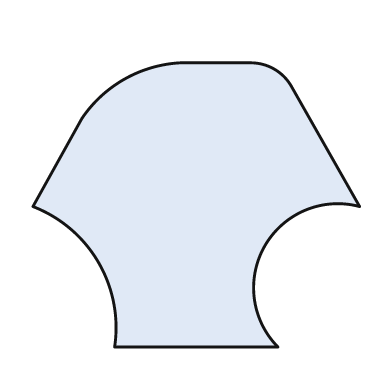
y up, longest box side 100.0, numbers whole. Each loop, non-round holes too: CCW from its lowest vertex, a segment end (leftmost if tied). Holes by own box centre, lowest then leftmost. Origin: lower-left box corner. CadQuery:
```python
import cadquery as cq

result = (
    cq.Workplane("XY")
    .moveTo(25.0, 0.0)
    .lineTo(75.0, 0.0)
    .threePointArc((71.0, 31.0), (100.0, 43.0))
    .lineTo(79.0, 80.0)
    .threePointArc((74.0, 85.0), (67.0, 87.0))
    .lineTo(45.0, 87.0)
    .threePointArc((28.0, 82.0), (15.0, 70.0))
    .lineTo(0.0, 43.0)
    .threePointArc((20.0, 26.0), (25.0, 0.0))
    .close()
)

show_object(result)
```